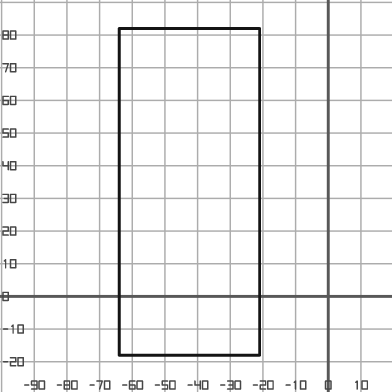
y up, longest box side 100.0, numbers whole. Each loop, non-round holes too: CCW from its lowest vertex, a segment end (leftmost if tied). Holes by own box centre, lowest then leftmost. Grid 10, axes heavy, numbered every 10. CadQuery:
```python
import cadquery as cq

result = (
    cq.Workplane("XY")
    .moveTo(-64.0, -18.0)
    .lineTo(-21.0, -18.0)
    .lineTo(-21.0, 82.0)
    .lineTo(-64.0, 82.0)
    .close()
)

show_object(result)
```